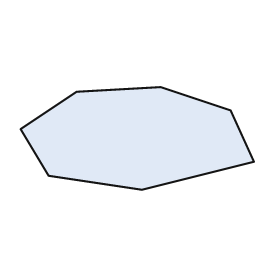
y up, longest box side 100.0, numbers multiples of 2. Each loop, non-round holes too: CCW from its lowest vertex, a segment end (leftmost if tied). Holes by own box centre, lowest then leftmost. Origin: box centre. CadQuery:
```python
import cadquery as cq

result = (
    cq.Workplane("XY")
    .moveTo(2.0, -22.0)
    .lineTo(50.0, -10.0)
    .lineTo(40.0, 12.0)
    .lineTo(10.0, 22.0)
    .lineTo(-26.0, 20.0)
    .lineTo(-50.0, 4.0)
    .lineTo(-38.0, -16.0)
    .close()
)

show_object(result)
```